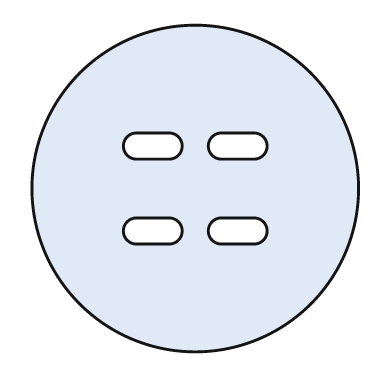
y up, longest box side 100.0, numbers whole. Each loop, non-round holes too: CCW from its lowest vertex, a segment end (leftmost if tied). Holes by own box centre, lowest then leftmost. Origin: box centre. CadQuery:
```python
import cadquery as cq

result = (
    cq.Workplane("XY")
    .moveTo(0.0, 0.0)
    .circle(50.0)
    .moveTo(-18.0, -17.0)
    .lineTo(-8.0, -17.0)
    .threePointArc((-4.0, -13.0), (-8.0, -9.0))
    .lineTo(-18.0, -9.0)
    .threePointArc((-22.0, -13.0), (-18.0, -17.0))
    .close()
    .moveTo(8.0, -17.0)
    .lineTo(18.0, -17.0)
    .threePointArc((22.0, -13.0), (18.0, -9.0))
    .lineTo(8.0, -9.0)
    .threePointArc((4.0, -13.0), (8.0, -17.0))
    .close()
    .moveTo(-18.0, 9.0)
    .lineTo(-8.0, 9.0)
    .threePointArc((-4.0, 13.0), (-8.0, 17.0))
    .lineTo(-18.0, 17.0)
    .threePointArc((-22.0, 13.0), (-18.0, 9.0))
    .close()
    .moveTo(8.0, 9.0)
    .lineTo(18.0, 9.0)
    .threePointArc((22.0, 13.0), (18.0, 17.0))
    .lineTo(8.0, 17.0)
    .threePointArc((4.0, 13.0), (8.0, 9.0))
    .close()
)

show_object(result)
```